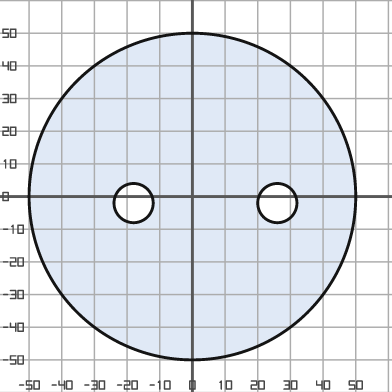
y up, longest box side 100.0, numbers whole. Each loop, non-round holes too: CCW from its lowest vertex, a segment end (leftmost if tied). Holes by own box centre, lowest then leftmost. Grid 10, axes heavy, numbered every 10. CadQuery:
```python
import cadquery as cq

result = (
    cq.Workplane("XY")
    .moveTo(0.0, 0.0)
    .circle(50.0)
    .moveTo(-18.0, -2.0)
    .circle(6.0)
    .moveTo(26.0, -2.0)
    .circle(6.0)
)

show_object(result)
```